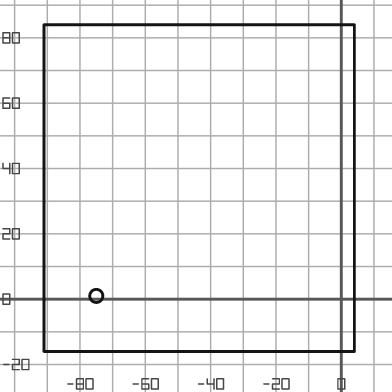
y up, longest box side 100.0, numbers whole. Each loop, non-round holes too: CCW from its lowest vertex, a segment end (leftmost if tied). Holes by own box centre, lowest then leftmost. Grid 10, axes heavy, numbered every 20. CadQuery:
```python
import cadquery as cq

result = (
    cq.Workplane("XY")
    .moveTo(-91.0, -16.0)
    .lineTo(4.0, -16.0)
    .lineTo(4.0, 84.0)
    .lineTo(-91.0, 84.0)
    .close()
    .moveTo(-75.0, 1.0)
    .circle(2.0)
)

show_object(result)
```